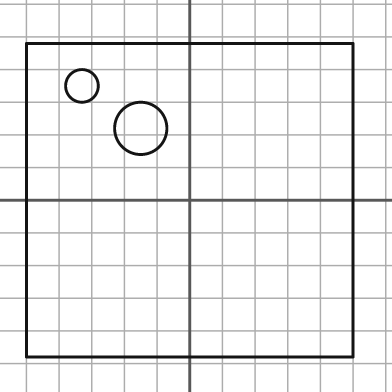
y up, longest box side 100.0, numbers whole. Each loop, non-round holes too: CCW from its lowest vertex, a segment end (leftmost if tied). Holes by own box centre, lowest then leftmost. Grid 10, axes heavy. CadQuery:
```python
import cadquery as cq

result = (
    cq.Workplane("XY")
    .moveTo(-50.0, -48.0)
    .lineTo(50.0, -48.0)
    .lineTo(50.0, 48.0)
    .lineTo(-50.0, 48.0)
    .close()
    .moveTo(-15.0, 22.0)
    .circle(8.0)
    .moveTo(-33.0, 35.0)
    .circle(5.0)
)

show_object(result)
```